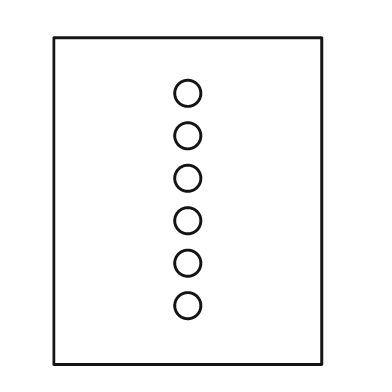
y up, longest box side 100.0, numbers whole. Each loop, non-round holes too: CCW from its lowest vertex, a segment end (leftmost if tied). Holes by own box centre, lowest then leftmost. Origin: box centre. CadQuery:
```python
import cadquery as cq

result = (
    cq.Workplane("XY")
    .moveTo(-41.0, -50.0)
    .lineTo(41.0, -50.0)
    .lineTo(41.0, 50.0)
    .lineTo(-41.0, 50.0)
    .close()
    .moveTo(0.0, -32.0)
    .circle(4.0)
    .moveTo(0.0, -19.0)
    .circle(4.0)
    .moveTo(0.0, -6.0)
    .circle(4.0)
    .moveTo(0.0, 7.0)
    .circle(4.0)
    .moveTo(0.0, 20.0)
    .circle(4.0)
    .moveTo(0.0, 33.0)
    .circle(4.0)
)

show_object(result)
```